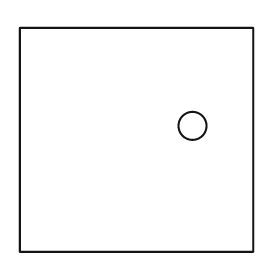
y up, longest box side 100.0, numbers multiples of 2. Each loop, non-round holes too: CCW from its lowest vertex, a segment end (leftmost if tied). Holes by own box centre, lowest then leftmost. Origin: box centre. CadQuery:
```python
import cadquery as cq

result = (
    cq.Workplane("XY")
    .moveTo(-50.0, -48.0)
    .lineTo(50.0, -48.0)
    .lineTo(50.0, 48.0)
    .lineTo(-50.0, 48.0)
    .close()
    .moveTo(24.0, 6.0)
    .circle(6.0)
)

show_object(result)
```